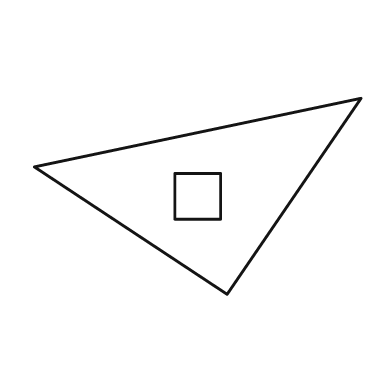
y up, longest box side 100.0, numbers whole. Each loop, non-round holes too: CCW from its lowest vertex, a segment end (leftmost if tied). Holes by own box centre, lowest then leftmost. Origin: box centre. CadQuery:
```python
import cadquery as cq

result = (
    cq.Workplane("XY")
    .moveTo(9.0, -30.0)
    .lineTo(50.0, 30.0)
    .lineTo(-50.0, 9.0)
    .close()
    .moveTo(-7.0, -7.0)
    .lineTo(7.0, -7.0)
    .lineTo(7.0, 7.0)
    .lineTo(-7.0, 7.0)
    .close()
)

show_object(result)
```